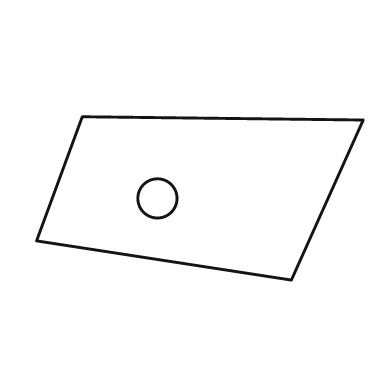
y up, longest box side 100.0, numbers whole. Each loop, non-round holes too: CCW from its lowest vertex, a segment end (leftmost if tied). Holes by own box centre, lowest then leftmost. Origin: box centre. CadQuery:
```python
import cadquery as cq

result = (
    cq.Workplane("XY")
    .moveTo(28.0, -25.0)
    .lineTo(50.0, 24.0)
    .lineTo(-36.0, 25.0)
    .lineTo(-50.0, -13.0)
    .close()
    .moveTo(-13.0, 0.0)
    .circle(6.0)
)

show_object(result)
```